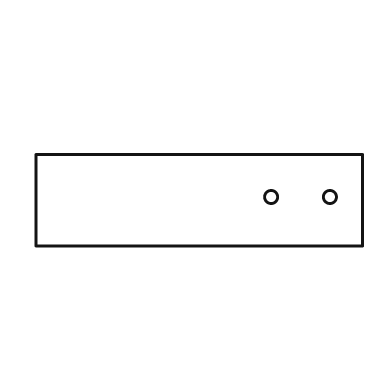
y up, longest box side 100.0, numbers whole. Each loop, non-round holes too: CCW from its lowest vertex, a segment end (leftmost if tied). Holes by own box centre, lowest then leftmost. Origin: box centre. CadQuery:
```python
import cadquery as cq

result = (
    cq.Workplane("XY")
    .moveTo(-50.0, -14.0)
    .lineTo(50.0, -14.0)
    .lineTo(50.0, 14.0)
    .lineTo(-50.0, 14.0)
    .close()
    .moveTo(22.0, 1.0)
    .circle(2.0)
    .moveTo(40.0, 1.0)
    .circle(2.0)
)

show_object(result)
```